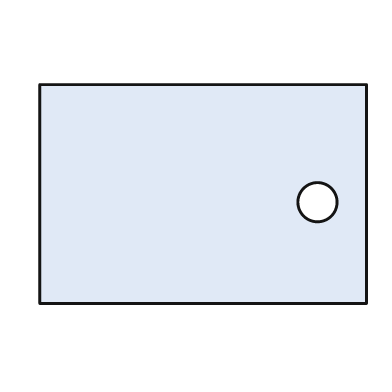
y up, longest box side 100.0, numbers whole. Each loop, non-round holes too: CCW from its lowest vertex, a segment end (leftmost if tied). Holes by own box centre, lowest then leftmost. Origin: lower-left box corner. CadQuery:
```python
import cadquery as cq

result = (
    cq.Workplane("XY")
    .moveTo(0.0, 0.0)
    .lineTo(100.0, 0.0)
    .lineTo(100.0, 67.0)
    .lineTo(0.0, 67.0)
    .close()
    .moveTo(85.0, 31.0)
    .circle(6.0)
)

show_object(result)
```